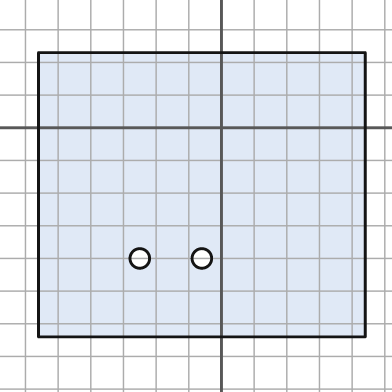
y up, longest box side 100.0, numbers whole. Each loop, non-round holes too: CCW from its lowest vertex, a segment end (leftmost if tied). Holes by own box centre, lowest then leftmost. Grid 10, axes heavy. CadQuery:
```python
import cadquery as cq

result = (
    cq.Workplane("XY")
    .moveTo(-56.0, -64.0)
    .lineTo(44.0, -64.0)
    .lineTo(44.0, 23.0)
    .lineTo(-56.0, 23.0)
    .close()
    .moveTo(-25.0, -40.0)
    .circle(3.0)
    .moveTo(-6.0, -40.0)
    .circle(3.0)
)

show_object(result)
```